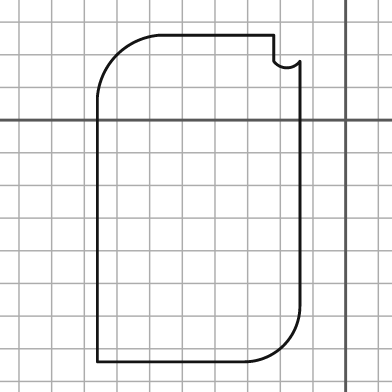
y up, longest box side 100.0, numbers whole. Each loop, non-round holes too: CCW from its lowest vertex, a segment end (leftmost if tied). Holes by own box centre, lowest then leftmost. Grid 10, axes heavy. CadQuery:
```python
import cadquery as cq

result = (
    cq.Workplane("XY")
    .moveTo(-76.0, -74.0)
    .lineTo(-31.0, -74.0)
    .threePointArc((-19.0, -69.0), (-14.0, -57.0))
    .lineTo(-14.0, 18.0)
    .threePointArc((-18.0, 16.0), (-22.0, 18.0))
    .lineTo(-22.0, 26.0)
    .lineTo(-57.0, 26.0)
    .threePointArc((-70.0, 20.0), (-76.0, 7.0))
    .close()
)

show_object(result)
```